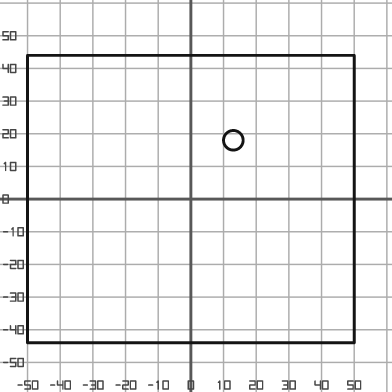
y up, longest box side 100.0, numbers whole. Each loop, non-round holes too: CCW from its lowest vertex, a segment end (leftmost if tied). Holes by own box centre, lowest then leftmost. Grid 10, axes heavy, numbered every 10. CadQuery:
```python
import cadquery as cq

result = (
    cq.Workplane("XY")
    .moveTo(-50.0, -44.0)
    .lineTo(50.0, -44.0)
    .lineTo(50.0, 44.0)
    .lineTo(-50.0, 44.0)
    .close()
    .moveTo(13.0, 18.0)
    .circle(3.0)
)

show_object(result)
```